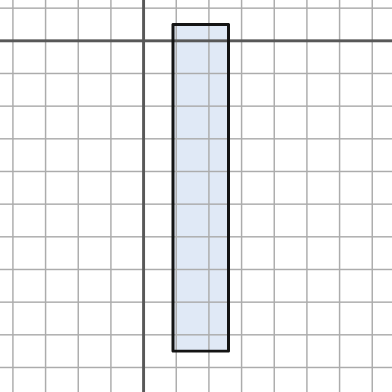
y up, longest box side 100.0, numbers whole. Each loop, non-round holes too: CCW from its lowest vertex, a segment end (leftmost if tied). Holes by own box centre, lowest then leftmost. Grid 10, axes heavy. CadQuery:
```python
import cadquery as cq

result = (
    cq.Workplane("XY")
    .moveTo(9.0, -95.0)
    .lineTo(26.0, -95.0)
    .lineTo(26.0, 5.0)
    .lineTo(9.0, 5.0)
    .close()
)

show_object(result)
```